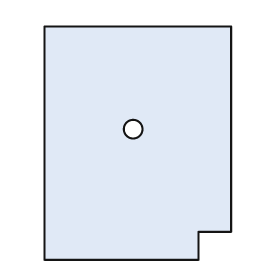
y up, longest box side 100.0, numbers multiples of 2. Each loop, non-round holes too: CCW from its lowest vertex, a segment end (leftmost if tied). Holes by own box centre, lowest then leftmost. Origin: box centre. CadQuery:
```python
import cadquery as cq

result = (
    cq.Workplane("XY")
    .moveTo(-40.0, -50.0)
    .lineTo(26.0, -50.0)
    .lineTo(26.0, -38.0)
    .lineTo(40.0, -38.0)
    .lineTo(40.0, 50.0)
    .lineTo(-40.0, 50.0)
    .close()
    .moveTo(-2.0, 6.0)
    .circle(4.0)
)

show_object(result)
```